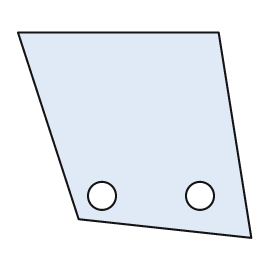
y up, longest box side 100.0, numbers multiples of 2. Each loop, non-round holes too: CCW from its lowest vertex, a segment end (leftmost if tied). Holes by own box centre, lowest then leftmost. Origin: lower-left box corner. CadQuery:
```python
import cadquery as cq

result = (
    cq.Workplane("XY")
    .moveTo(100.0, 0.0)
    .lineTo(86.0, 88.0)
    .lineTo(0.0, 88.0)
    .lineTo(26.0, 8.0)
    .close()
    .moveTo(36.0, 18.0)
    .circle(6.0)
    .moveTo(78.0, 18.0)
    .circle(6.0)
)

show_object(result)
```